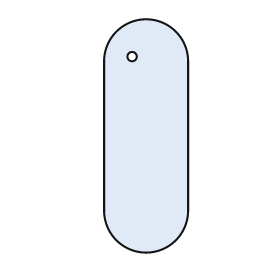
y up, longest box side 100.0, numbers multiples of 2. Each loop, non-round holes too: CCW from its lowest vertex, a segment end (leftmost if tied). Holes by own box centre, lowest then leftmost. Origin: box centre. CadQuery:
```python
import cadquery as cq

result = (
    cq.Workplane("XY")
    .moveTo(-18.0, -32.0)
    .threePointArc((0.0, -50.0), (18.0, -32.0))
    .lineTo(18.0, 32.0)
    .threePointArc((0.0, 50.0), (-18.0, 32.0))
    .close()
    .moveTo(-6.0, 34.0)
    .circle(2.0)
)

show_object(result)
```